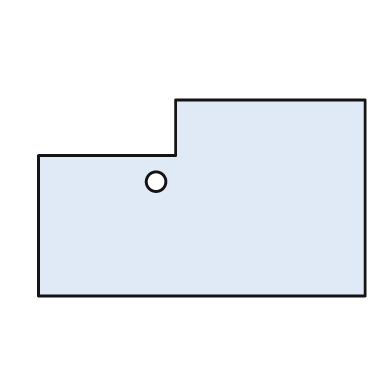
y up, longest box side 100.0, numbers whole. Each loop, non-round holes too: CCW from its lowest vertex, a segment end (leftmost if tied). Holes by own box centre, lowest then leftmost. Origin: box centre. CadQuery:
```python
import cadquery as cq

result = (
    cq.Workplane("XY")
    .moveTo(-50.0, -30.0)
    .lineTo(50.0, -30.0)
    .lineTo(50.0, 30.0)
    .lineTo(-8.0, 30.0)
    .lineTo(-8.0, 13.0)
    .lineTo(-50.0, 13.0)
    .close()
    .moveTo(-14.0, 5.0)
    .circle(3.0)
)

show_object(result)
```